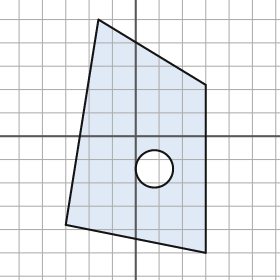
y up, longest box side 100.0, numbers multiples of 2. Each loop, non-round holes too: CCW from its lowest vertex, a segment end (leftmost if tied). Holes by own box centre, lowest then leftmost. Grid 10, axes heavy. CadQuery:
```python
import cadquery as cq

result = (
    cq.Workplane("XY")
    .moveTo(30.0, -50.0)
    .lineTo(30.0, 22.0)
    .lineTo(-16.0, 50.0)
    .lineTo(-30.0, -38.0)
    .close()
    .moveTo(8.0, -14.0)
    .circle(8.0)
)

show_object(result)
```